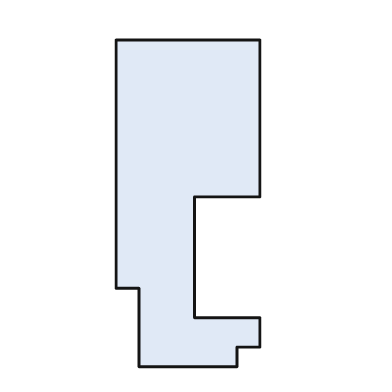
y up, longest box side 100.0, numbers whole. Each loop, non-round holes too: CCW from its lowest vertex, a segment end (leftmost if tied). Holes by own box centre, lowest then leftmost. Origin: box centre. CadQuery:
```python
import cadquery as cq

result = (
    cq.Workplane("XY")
    .moveTo(-15.0, -50.0)
    .lineTo(15.0, -50.0)
    .lineTo(15.0, -44.0)
    .lineTo(22.0, -44.0)
    .lineTo(22.0, -35.0)
    .lineTo(2.0, -35.0)
    .lineTo(2.0, 2.0)
    .lineTo(22.0, 2.0)
    .lineTo(22.0, 50.0)
    .lineTo(-22.0, 50.0)
    .lineTo(-22.0, -26.0)
    .lineTo(-15.0, -26.0)
    .close()
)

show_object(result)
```